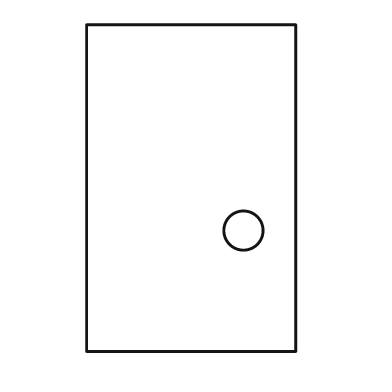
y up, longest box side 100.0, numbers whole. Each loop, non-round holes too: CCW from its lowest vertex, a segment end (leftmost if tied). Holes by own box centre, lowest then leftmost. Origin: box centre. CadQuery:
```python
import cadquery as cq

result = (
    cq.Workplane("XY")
    .moveTo(-32.0, -50.0)
    .lineTo(32.0, -50.0)
    .lineTo(32.0, 50.0)
    .lineTo(-32.0, 50.0)
    .close()
    .moveTo(16.0, -13.0)
    .circle(6.0)
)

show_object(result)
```